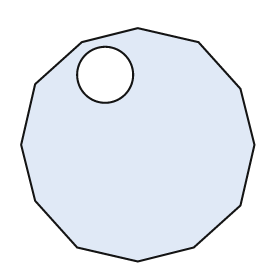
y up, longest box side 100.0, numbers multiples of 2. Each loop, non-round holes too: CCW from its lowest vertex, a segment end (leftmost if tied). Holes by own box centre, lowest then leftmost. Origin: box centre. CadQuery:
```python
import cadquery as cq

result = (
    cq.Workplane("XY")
    .moveTo(0.0, -50.0)
    .lineTo(24.0, -44.0)
    .lineTo(44.0, -26.0)
    .lineTo(50.0, 0.0)
    .lineTo(44.0, 24.0)
    .lineTo(26.0, 44.0)
    .lineTo(0.0, 50.0)
    .lineTo(-24.0, 44.0)
    .lineTo(-44.0, 26.0)
    .lineTo(-50.0, 0.0)
    .lineTo(-44.0, -24.0)
    .lineTo(-26.0, -44.0)
    .close()
    .moveTo(-14.0, 30.0)
    .circle(12.0)
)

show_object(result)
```